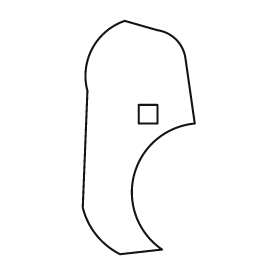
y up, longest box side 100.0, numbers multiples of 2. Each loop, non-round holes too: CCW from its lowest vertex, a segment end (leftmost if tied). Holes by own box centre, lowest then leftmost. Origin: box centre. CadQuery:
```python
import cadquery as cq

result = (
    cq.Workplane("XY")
    .moveTo(-8.0, -50.0)
    .lineTo(10.0, -48.0)
    .threePointArc((-2.0, -16.0), (24.0, 6.0))
    .lineTo(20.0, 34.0)
    .threePointArc((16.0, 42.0), (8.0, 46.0))
    .lineTo(-6.0, 50.0)
    .threePointArc((-20.0, 38.0), (-22.0, 20.0))
    .lineTo(-24.0, -30.0)
    .threePointArc((-18.0, -42.0), (-8.0, -50.0))
    .close()
    .moveTo(0.0, 6.0)
    .lineTo(8.0, 6.0)
    .lineTo(8.0, 14.0)
    .lineTo(0.0, 14.0)
    .close()
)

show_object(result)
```